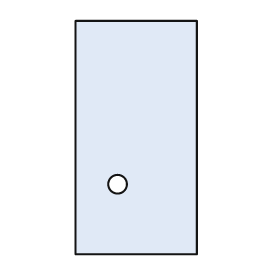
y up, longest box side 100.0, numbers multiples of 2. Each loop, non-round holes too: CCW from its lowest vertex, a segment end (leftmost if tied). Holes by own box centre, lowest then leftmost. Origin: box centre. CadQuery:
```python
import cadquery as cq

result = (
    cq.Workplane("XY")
    .moveTo(-26.0, -50.0)
    .lineTo(26.0, -50.0)
    .lineTo(26.0, 50.0)
    .lineTo(-26.0, 50.0)
    .close()
    .moveTo(-8.0, -20.0)
    .circle(4.0)
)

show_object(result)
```